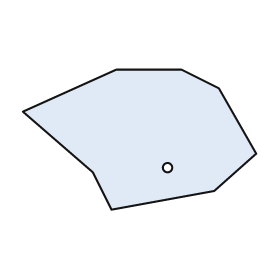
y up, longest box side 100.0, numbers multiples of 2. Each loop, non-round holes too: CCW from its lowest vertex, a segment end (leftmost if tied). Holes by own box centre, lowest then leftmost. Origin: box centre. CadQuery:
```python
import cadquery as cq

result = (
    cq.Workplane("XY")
    .moveTo(-12.0, -30.0)
    .lineTo(32.0, -22.0)
    .lineTo(50.0, -6.0)
    .lineTo(34.0, 22.0)
    .lineTo(18.0, 30.0)
    .lineTo(-10.0, 30.0)
    .lineTo(-50.0, 12.0)
    .lineTo(-20.0, -14.0)
    .close()
    .moveTo(12.0, -12.0)
    .circle(2.0)
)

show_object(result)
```